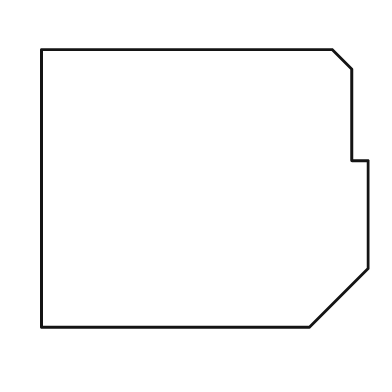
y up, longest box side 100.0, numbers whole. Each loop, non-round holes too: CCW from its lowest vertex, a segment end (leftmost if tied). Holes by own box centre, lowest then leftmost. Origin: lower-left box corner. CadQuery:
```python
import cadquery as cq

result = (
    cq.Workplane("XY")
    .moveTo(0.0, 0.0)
    .lineTo(82.0, 0.0)
    .lineTo(100.0, 18.0)
    .lineTo(100.0, 51.0)
    .lineTo(95.0, 51.0)
    .lineTo(95.0, 79.0)
    .lineTo(89.0, 85.0)
    .lineTo(0.0, 85.0)
    .close()
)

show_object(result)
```